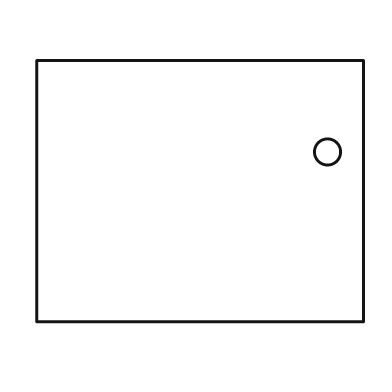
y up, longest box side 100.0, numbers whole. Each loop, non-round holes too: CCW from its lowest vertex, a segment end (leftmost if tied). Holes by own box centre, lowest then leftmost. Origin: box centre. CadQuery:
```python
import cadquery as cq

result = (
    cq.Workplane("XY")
    .moveTo(-50.0, -40.0)
    .lineTo(50.0, -40.0)
    .lineTo(50.0, 40.0)
    .lineTo(-50.0, 40.0)
    .close()
    .moveTo(39.0, 12.0)
    .circle(4.0)
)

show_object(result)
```